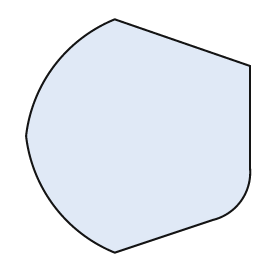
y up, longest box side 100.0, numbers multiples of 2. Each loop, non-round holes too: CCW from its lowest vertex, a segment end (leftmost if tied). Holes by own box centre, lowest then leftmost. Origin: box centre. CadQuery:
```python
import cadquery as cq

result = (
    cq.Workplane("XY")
    .moveTo(-10.0, -50.0)
    .lineTo(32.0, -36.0)
    .threePointArc((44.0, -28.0), (48.0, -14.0))
    .lineTo(48.0, 30.0)
    .lineTo(-10.0, 50.0)
    .threePointArc((-36.0, 30.0), (-48.0, 0.0))
    .threePointArc((-36.0, -30.0), (-10.0, -50.0))
    .close()
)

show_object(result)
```